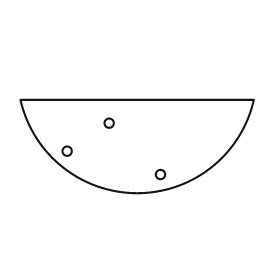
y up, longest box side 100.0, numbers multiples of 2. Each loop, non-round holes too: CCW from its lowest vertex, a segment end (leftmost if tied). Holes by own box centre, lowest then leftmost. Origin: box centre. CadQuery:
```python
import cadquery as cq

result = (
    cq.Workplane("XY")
    .moveTo(-50.0, 20.0)
    .threePointArc((0.0, -20.0), (50.0, 20.0))
    .close()
    .moveTo(10.0, -12.0)
    .circle(2.0)
    .moveTo(-30.0, -2.0)
    .circle(2.0)
    .moveTo(-12.0, 10.0)
    .circle(2.0)
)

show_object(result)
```